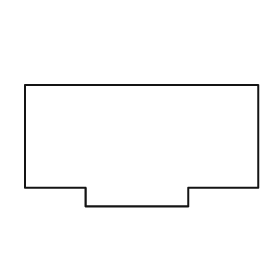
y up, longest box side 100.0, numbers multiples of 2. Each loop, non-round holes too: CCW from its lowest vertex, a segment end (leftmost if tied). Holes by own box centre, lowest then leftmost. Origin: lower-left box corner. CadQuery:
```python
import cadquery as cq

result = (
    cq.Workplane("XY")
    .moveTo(26.0, 0.0)
    .lineTo(70.0, 0.0)
    .lineTo(70.0, 8.0)
    .lineTo(100.0, 8.0)
    .lineTo(100.0, 52.0)
    .lineTo(0.0, 52.0)
    .lineTo(0.0, 8.0)
    .lineTo(26.0, 8.0)
    .close()
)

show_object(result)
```